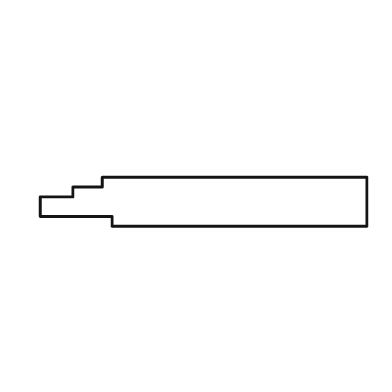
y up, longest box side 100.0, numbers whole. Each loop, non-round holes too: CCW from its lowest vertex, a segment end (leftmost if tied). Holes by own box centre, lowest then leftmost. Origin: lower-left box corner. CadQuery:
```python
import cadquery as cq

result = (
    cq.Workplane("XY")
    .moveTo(22.0, 0.0)
    .lineTo(100.0, 0.0)
    .lineTo(100.0, 15.0)
    .lineTo(19.0, 15.0)
    .lineTo(19.0, 12.0)
    .lineTo(10.0, 12.0)
    .lineTo(10.0, 9.0)
    .lineTo(0.0, 9.0)
    .lineTo(0.0, 3.0)
    .lineTo(22.0, 3.0)
    .close()
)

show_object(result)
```